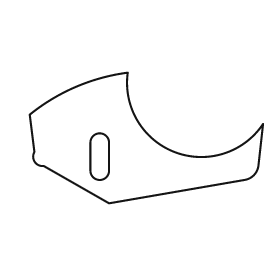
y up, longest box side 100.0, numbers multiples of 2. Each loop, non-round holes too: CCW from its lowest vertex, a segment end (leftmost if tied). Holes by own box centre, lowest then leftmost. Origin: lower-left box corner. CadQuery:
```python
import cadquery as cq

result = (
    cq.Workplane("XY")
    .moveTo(34.0, 0.0)
    .lineTo(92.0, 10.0)
    .threePointArc((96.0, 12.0), (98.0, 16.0))
    .lineTo(100.0, 34.0)
    .threePointArc((62.0, 22.0), (42.0, 56.0))
    .threePointArc((20.0, 50.0), (0.0, 38.0))
    .lineTo(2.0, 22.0)
    .threePointArc((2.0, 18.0), (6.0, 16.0))
    .close()
    .moveTo(26.0, 14.0)
    .threePointArc((30.0, 10.0), (34.0, 14.0))
    .lineTo(34.0, 26.0)
    .threePointArc((30.0, 30.0), (26.0, 26.0))
    .close()
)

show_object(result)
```